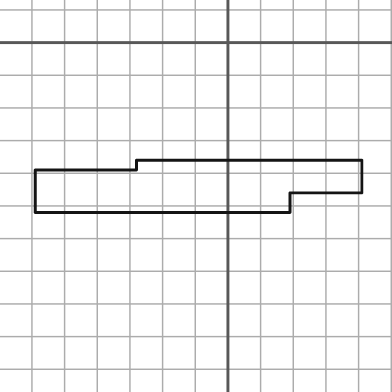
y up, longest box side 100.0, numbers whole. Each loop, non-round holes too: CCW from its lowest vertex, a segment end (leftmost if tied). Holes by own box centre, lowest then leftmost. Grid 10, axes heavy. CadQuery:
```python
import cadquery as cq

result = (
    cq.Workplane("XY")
    .moveTo(-59.0, -52.0)
    .lineTo(19.0, -52.0)
    .lineTo(19.0, -46.0)
    .lineTo(41.0, -46.0)
    .lineTo(41.0, -36.0)
    .lineTo(-28.0, -36.0)
    .lineTo(-28.0, -39.0)
    .lineTo(-59.0, -39.0)
    .close()
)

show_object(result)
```